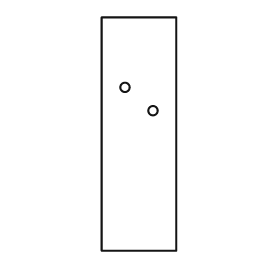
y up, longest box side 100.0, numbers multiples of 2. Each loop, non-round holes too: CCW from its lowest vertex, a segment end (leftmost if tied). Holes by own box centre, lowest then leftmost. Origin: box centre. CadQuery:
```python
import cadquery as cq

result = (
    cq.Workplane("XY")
    .moveTo(-16.0, -50.0)
    .lineTo(16.0, -50.0)
    .lineTo(16.0, 50.0)
    .lineTo(-16.0, 50.0)
    .close()
    .moveTo(6.0, 10.0)
    .circle(2.0)
    .moveTo(-6.0, 20.0)
    .circle(2.0)
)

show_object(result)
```